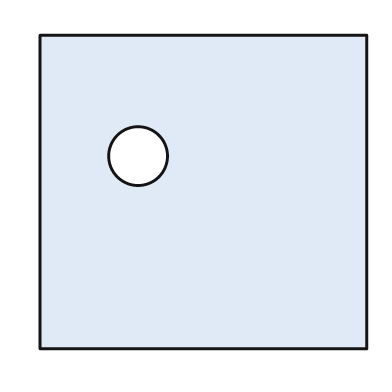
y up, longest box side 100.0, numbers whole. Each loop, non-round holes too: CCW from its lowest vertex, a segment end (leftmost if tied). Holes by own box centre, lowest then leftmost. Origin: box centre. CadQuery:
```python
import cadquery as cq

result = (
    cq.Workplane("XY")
    .moveTo(-50.0, -48.0)
    .lineTo(50.0, -48.0)
    .lineTo(50.0, 48.0)
    .lineTo(-50.0, 48.0)
    .close()
    .moveTo(-20.0, 11.0)
    .circle(9.0)
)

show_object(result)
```